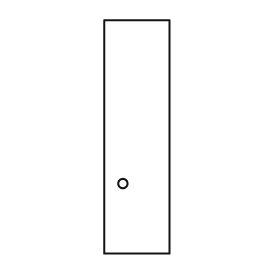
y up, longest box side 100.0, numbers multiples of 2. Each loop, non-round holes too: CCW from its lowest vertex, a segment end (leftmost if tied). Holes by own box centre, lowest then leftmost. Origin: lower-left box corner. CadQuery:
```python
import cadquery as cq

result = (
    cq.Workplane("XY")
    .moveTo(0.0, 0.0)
    .lineTo(28.0, 0.0)
    .lineTo(28.0, 100.0)
    .lineTo(0.0, 100.0)
    .close()
    .moveTo(8.0, 30.0)
    .circle(2.0)
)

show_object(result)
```